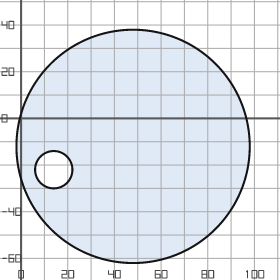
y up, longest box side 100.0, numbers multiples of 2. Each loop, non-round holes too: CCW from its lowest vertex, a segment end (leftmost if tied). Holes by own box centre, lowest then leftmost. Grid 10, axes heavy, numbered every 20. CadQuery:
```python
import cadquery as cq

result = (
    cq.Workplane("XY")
    .moveTo(48.0, -12.0)
    .circle(50.0)
    .moveTo(14.0, -22.0)
    .circle(8.0)
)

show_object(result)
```